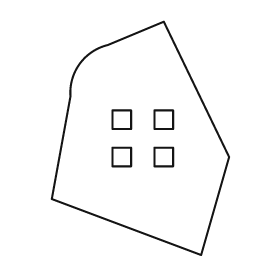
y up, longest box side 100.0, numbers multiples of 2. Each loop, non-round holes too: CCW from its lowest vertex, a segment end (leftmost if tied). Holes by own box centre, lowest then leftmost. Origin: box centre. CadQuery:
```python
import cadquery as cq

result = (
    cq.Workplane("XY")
    .moveTo(26.0, -50.0)
    .lineTo(38.0, -8.0)
    .lineTo(10.0, 50.0)
    .lineTo(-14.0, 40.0)
    .threePointArc((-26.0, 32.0), (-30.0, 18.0))
    .lineTo(-38.0, -26.0)
    .close()
    .moveTo(-12.0, -12.0)
    .lineTo(-4.0, -12.0)
    .lineTo(-4.0, -4.0)
    .lineTo(-12.0, -4.0)
    .close()
    .moveTo(6.0, -12.0)
    .lineTo(14.0, -12.0)
    .lineTo(14.0, -4.0)
    .lineTo(6.0, -4.0)
    .close()
    .moveTo(-12.0, 4.0)
    .lineTo(-4.0, 4.0)
    .lineTo(-4.0, 12.0)
    .lineTo(-12.0, 12.0)
    .close()
    .moveTo(6.0, 4.0)
    .lineTo(14.0, 4.0)
    .lineTo(14.0, 12.0)
    .lineTo(6.0, 12.0)
    .close()
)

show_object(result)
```